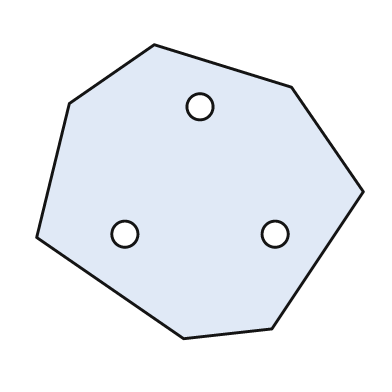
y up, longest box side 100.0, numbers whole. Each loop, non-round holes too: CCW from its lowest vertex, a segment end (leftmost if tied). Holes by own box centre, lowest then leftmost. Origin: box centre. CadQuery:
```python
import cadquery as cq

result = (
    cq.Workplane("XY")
    .moveTo(-5.0, -45.0)
    .lineTo(22.0, -42.0)
    .lineTo(50.0, 0.0)
    .lineTo(28.0, 32.0)
    .lineTo(-14.0, 45.0)
    .lineTo(-40.0, 27.0)
    .lineTo(-50.0, -14.0)
    .close()
    .moveTo(-23.0, -13.0)
    .circle(4.0)
    .moveTo(23.0, -13.0)
    .circle(4.0)
    .moveTo(0.0, 26.0)
    .circle(4.0)
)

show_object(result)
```